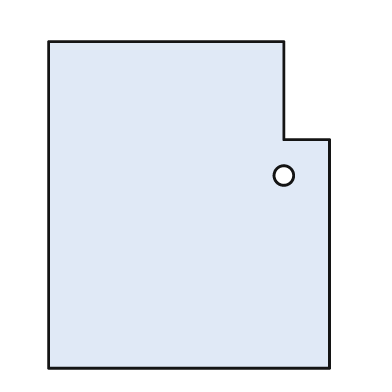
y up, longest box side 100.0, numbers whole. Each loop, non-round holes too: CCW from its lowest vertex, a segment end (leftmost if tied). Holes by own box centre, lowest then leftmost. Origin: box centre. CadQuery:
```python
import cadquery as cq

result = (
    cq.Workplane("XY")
    .moveTo(-43.0, -50.0)
    .lineTo(43.0, -50.0)
    .lineTo(43.0, 20.0)
    .lineTo(29.0, 20.0)
    .lineTo(29.0, 50.0)
    .lineTo(-43.0, 50.0)
    .close()
    .moveTo(29.0, 9.0)
    .circle(3.0)
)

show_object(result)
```